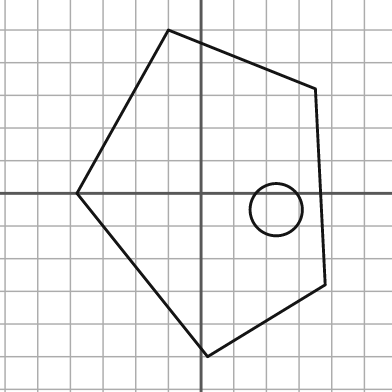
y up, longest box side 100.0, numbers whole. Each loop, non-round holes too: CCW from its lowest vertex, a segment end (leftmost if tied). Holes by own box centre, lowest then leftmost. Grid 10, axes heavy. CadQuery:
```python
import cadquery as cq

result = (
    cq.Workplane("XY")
    .moveTo(2.0, -50.0)
    .lineTo(38.0, -28.0)
    .lineTo(35.0, 32.0)
    .lineTo(-10.0, 50.0)
    .lineTo(-38.0, 0.0)
    .close()
    .moveTo(23.0, -5.0)
    .circle(8.0)
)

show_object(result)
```